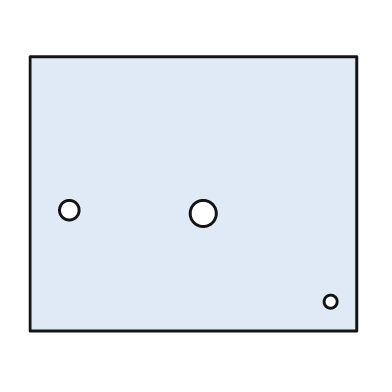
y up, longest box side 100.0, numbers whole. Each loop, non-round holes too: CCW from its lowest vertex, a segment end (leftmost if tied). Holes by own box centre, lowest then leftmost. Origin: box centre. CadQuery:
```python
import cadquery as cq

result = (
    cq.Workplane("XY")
    .moveTo(-50.0, -42.0)
    .lineTo(50.0, -42.0)
    .lineTo(50.0, 42.0)
    .lineTo(-50.0, 42.0)
    .close()
    .moveTo(42.0, -33.0)
    .circle(2.0)
    .moveTo(3.0, -6.0)
    .circle(4.0)
    .moveTo(-38.0, -5.0)
    .circle(3.0)
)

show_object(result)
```